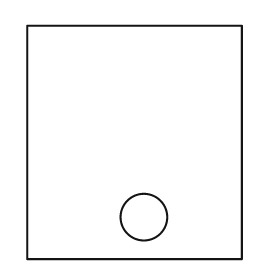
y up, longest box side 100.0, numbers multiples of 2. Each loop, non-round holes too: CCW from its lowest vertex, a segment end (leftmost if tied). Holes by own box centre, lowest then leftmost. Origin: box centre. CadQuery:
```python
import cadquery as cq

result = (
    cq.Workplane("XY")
    .moveTo(-46.0, -50.0)
    .lineTo(46.0, -50.0)
    .lineTo(46.0, 50.0)
    .lineTo(-46.0, 50.0)
    .close()
    .moveTo(4.0, -32.0)
    .circle(10.0)
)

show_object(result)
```